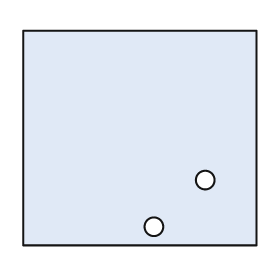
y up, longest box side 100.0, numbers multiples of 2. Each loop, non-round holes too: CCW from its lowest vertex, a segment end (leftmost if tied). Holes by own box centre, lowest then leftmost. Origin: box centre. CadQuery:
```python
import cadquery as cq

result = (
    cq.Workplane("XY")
    .moveTo(-50.0, -46.0)
    .lineTo(50.0, -46.0)
    .lineTo(50.0, 46.0)
    .lineTo(-50.0, 46.0)
    .close()
    .moveTo(6.0, -38.0)
    .circle(4.0)
    .moveTo(28.0, -18.0)
    .circle(4.0)
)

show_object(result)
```